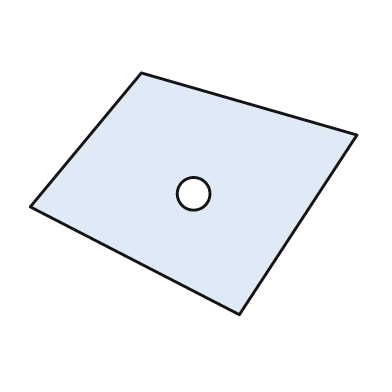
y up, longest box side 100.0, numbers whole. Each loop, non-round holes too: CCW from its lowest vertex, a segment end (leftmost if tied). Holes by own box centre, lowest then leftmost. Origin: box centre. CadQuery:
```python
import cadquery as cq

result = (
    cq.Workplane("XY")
    .moveTo(14.0, -37.0)
    .lineTo(50.0, 18.0)
    .lineTo(-16.0, 37.0)
    .lineTo(-50.0, -4.0)
    .close()
    .moveTo(0.0, 0.0)
    .circle(5.0)
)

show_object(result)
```